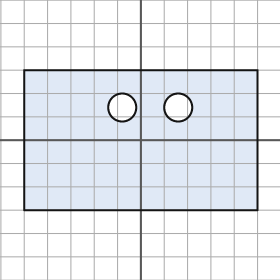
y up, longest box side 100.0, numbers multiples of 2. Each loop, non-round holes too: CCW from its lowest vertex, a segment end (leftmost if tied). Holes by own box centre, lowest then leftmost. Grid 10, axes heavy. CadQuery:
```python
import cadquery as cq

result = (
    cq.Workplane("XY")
    .moveTo(-50.0, -30.0)
    .lineTo(50.0, -30.0)
    .lineTo(50.0, 30.0)
    .lineTo(-50.0, 30.0)
    .close()
    .moveTo(-8.0, 14.0)
    .circle(6.0)
    .moveTo(16.0, 14.0)
    .circle(6.0)
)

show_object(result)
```